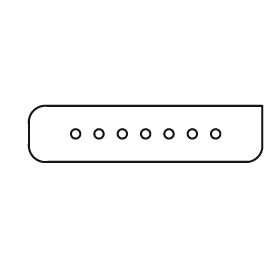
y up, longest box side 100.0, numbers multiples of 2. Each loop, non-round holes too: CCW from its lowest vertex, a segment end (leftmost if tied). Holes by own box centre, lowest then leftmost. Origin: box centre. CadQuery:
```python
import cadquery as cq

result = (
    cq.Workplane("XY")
    .moveTo(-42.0, -12.0)
    .lineTo(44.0, -12.0)
    .threePointArc((48.0, -10.0), (50.0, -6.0))
    .lineTo(50.0, 12.0)
    .lineTo(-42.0, 12.0)
    .threePointArc((-48.0, 10.0), (-50.0, 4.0))
    .lineTo(-50.0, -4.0)
    .threePointArc((-48.0, -10.0), (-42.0, -12.0))
    .close()
    .moveTo(-30.0, 0.0)
    .circle(2.0)
    .moveTo(-20.0, 0.0)
    .circle(2.0)
    .moveTo(-10.0, 0.0)
    .circle(2.0)
    .moveTo(0.0, 0.0)
    .circle(2.0)
    .moveTo(10.0, 0.0)
    .circle(2.0)
    .moveTo(20.0, 0.0)
    .circle(2.0)
    .moveTo(30.0, 0.0)
    .circle(2.0)
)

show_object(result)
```